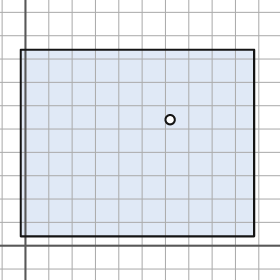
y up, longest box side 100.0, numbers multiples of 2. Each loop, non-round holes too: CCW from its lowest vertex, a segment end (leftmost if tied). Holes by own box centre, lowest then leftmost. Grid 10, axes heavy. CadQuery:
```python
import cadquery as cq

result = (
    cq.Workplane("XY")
    .moveTo(-2.0, 4.0)
    .lineTo(98.0, 4.0)
    .lineTo(98.0, 84.0)
    .lineTo(-2.0, 84.0)
    .close()
    .moveTo(62.0, 54.0)
    .circle(2.0)
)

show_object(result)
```